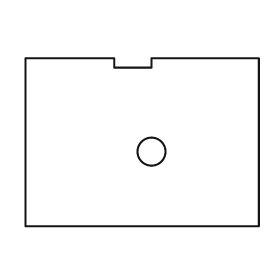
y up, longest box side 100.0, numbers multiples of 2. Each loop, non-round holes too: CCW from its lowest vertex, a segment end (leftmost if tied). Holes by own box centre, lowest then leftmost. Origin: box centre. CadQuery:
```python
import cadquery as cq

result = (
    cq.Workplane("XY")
    .moveTo(-50.0, -36.0)
    .lineTo(50.0, -36.0)
    .lineTo(50.0, 36.0)
    .lineTo(4.0, 36.0)
    .lineTo(4.0, 32.0)
    .lineTo(-12.0, 32.0)
    .lineTo(-12.0, 36.0)
    .lineTo(-50.0, 36.0)
    .close()
    .moveTo(4.0, -4.0)
    .circle(6.0)
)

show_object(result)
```